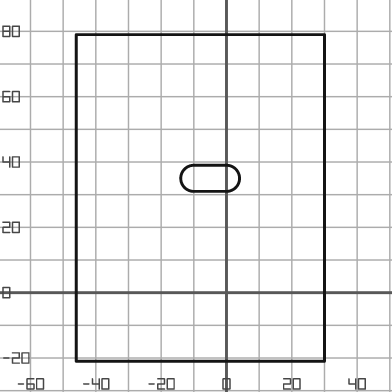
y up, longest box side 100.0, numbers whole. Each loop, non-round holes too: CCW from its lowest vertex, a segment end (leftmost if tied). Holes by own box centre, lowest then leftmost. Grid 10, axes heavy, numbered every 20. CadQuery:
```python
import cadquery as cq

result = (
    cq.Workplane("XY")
    .moveTo(-46.0, -21.0)
    .lineTo(30.0, -21.0)
    .lineTo(30.0, 79.0)
    .lineTo(-46.0, 79.0)
    .close()
    .moveTo(-10.0, 31.0)
    .lineTo(0.0, 31.0)
    .threePointArc((4.0, 35.0), (0.0, 39.0))
    .lineTo(-10.0, 39.0)
    .threePointArc((-14.0, 35.0), (-10.0, 31.0))
    .close()
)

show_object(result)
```